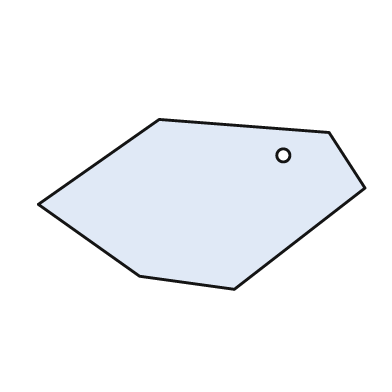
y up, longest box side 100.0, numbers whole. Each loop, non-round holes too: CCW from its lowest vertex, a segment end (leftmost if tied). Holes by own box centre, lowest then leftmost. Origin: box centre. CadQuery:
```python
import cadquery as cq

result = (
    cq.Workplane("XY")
    .moveTo(10.0, -26.0)
    .lineTo(50.0, 5.0)
    .lineTo(39.0, 22.0)
    .lineTo(-13.0, 26.0)
    .lineTo(-50.0, 0.0)
    .lineTo(-19.0, -22.0)
    .close()
    .moveTo(25.0, 15.0)
    .circle(2.0)
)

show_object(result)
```